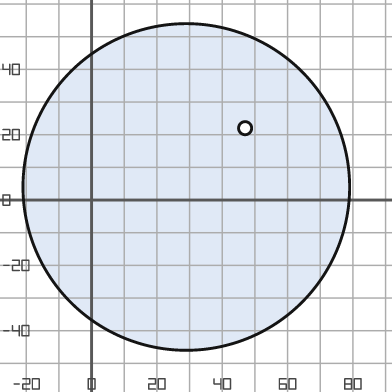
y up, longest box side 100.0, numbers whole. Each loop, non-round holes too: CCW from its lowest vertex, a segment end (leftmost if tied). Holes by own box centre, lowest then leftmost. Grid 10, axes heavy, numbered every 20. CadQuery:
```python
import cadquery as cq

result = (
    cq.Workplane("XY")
    .moveTo(29.0, 4.0)
    .circle(50.0)
    .moveTo(47.0, 22.0)
    .circle(2.0)
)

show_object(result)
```